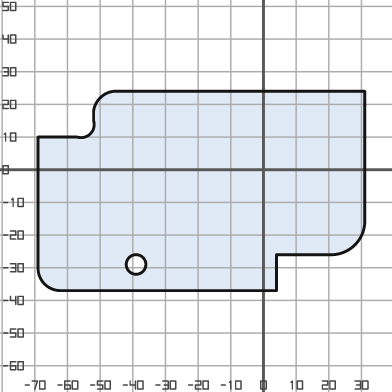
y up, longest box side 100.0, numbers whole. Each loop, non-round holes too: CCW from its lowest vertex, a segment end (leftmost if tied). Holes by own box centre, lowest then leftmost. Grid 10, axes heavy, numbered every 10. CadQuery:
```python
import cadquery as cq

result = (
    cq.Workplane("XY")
    .moveTo(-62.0, -37.0)
    .lineTo(4.0, -37.0)
    .lineTo(4.0, -26.0)
    .lineTo(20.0, -26.0)
    .threePointArc((28.0, -23.0), (31.0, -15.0))
    .lineTo(31.0, 24.0)
    .lineTo(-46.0, 24.0)
    .threePointArc((-50.0, 22.0), (-52.0, 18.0))
    .lineTo(-52.0, 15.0)
    .threePointArc((-53.0, 11.0), (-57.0, 10.0))
    .lineTo(-69.0, 10.0)
    .lineTo(-69.0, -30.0)
    .threePointArc((-67.0, -35.0), (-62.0, -37.0))
    .close()
    .moveTo(-39.0, -29.0)
    .circle(3.0)
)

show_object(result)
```